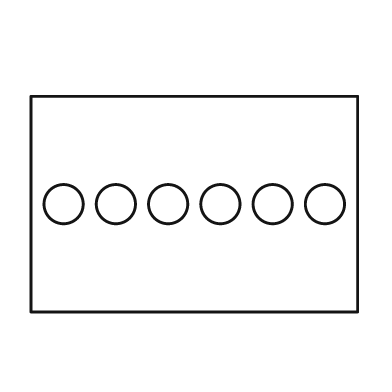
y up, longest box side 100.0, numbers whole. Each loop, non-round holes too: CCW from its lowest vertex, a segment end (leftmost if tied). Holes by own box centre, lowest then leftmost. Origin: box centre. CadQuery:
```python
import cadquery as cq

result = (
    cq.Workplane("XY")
    .moveTo(-50.0, -33.0)
    .lineTo(50.0, -33.0)
    .lineTo(50.0, 33.0)
    .lineTo(-50.0, 33.0)
    .close()
    .moveTo(-40.0, 0.0)
    .circle(6.0)
    .moveTo(-24.0, 0.0)
    .circle(6.0)
    .moveTo(-8.0, 0.0)
    .circle(6.0)
    .moveTo(8.0, 0.0)
    .circle(6.0)
    .moveTo(24.0, 0.0)
    .circle(6.0)
    .moveTo(40.0, 0.0)
    .circle(6.0)
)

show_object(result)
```